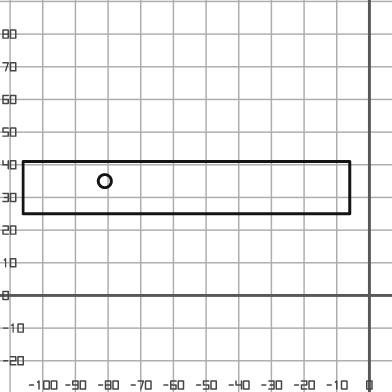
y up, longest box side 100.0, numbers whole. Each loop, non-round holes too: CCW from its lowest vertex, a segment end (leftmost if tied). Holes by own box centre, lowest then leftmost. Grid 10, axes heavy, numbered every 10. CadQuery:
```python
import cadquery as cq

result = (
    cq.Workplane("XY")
    .moveTo(-106.0, 25.0)
    .lineTo(-6.0, 25.0)
    .lineTo(-6.0, 41.0)
    .lineTo(-106.0, 41.0)
    .close()
    .moveTo(-81.0, 35.0)
    .circle(2.0)
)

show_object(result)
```